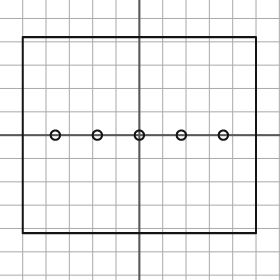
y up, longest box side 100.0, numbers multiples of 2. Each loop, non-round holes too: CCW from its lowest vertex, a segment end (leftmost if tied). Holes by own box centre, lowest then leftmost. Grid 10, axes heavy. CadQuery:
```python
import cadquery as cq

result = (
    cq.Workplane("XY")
    .moveTo(-50.0, -42.0)
    .lineTo(50.0, -42.0)
    .lineTo(50.0, 42.0)
    .lineTo(-50.0, 42.0)
    .close()
    .moveTo(-36.0, 0.0)
    .circle(2.0)
    .moveTo(-18.0, 0.0)
    .circle(2.0)
    .moveTo(0.0, 0.0)
    .circle(2.0)
    .moveTo(18.0, 0.0)
    .circle(2.0)
    .moveTo(36.0, 0.0)
    .circle(2.0)
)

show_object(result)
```